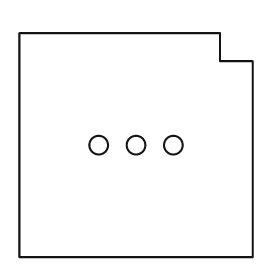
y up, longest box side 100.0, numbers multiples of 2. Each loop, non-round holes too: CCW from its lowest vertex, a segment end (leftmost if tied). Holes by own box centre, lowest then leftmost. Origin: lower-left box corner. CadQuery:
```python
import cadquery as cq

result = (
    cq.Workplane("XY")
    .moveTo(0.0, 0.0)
    .lineTo(100.0, 0.0)
    .lineTo(100.0, 84.0)
    .lineTo(86.0, 84.0)
    .lineTo(86.0, 96.0)
    .lineTo(0.0, 96.0)
    .close()
    .moveTo(34.0, 48.0)
    .circle(4.0)
    .moveTo(50.0, 48.0)
    .circle(4.0)
    .moveTo(66.0, 48.0)
    .circle(4.0)
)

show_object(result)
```